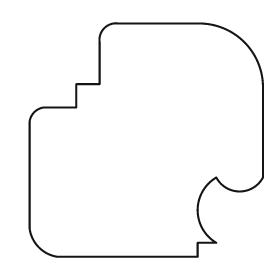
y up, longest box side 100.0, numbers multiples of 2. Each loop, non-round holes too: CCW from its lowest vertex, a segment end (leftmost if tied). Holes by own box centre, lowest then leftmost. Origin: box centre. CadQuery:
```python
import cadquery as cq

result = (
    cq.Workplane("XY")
    .moveTo(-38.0, -50.0)
    .lineTo(22.0, -50.0)
    .lineTo(22.0, -44.0)
    .lineTo(30.0, -44.0)
    .threePointArc((22.0, -30.0), (30.0, -16.0))
    .threePointArc((40.0, -22.0), (50.0, -16.0))
    .lineTo(50.0, 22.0)
    .threePointArc((42.0, 42.0), (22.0, 50.0))
    .lineTo(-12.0, 50.0)
    .threePointArc((-18.0, 48.0), (-20.0, 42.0))
    .lineTo(-20.0, 24.0)
    .lineTo(-30.0, 24.0)
    .lineTo(-30.0, 14.0)
    .lineTo(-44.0, 14.0)
    .threePointArc((-48.0, 12.0), (-50.0, 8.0))
    .lineTo(-50.0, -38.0)
    .threePointArc((-46.0, -46.0), (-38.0, -50.0))
    .close()
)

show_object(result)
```